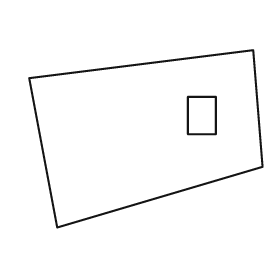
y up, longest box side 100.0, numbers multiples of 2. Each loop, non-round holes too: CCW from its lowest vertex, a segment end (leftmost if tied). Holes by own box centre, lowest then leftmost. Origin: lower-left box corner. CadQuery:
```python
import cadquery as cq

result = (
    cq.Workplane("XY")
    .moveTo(12.0, 0.0)
    .lineTo(100.0, 26.0)
    .lineTo(96.0, 76.0)
    .lineTo(0.0, 64.0)
    .close()
    .moveTo(68.0, 40.0)
    .lineTo(80.0, 40.0)
    .lineTo(80.0, 56.0)
    .lineTo(68.0, 56.0)
    .close()
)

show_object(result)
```